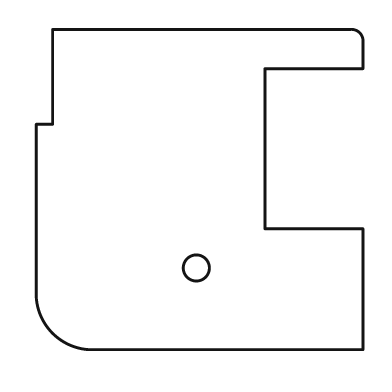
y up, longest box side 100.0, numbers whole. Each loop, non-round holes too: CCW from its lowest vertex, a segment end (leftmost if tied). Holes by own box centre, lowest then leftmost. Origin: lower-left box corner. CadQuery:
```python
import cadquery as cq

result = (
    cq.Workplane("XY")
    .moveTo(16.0, 0.0)
    .lineTo(100.0, 0.0)
    .lineTo(100.0, 37.0)
    .lineTo(70.0, 37.0)
    .lineTo(70.0, 86.0)
    .lineTo(100.0, 86.0)
    .lineTo(100.0, 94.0)
    .threePointArc((99.0, 97.0), (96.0, 98.0))
    .lineTo(5.0, 98.0)
    .lineTo(5.0, 69.0)
    .lineTo(0.0, 69.0)
    .lineTo(0.0, 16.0)
    .threePointArc((5.0, 5.0), (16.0, 0.0))
    .close()
    .moveTo(49.0, 25.0)
    .circle(4.0)
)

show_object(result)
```